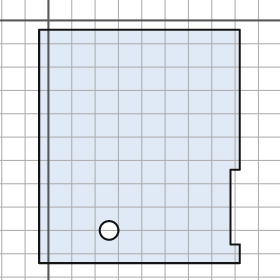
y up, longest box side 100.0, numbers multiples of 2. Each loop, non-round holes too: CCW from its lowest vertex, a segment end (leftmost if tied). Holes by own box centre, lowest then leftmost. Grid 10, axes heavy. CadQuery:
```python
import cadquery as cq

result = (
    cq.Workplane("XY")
    .moveTo(-4.0, -104.0)
    .lineTo(82.0, -104.0)
    .lineTo(82.0, -96.0)
    .lineTo(78.0, -96.0)
    .lineTo(78.0, -64.0)
    .lineTo(82.0, -64.0)
    .lineTo(82.0, -4.0)
    .lineTo(-4.0, -4.0)
    .close()
    .moveTo(26.0, -90.0)
    .circle(4.0)
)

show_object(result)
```